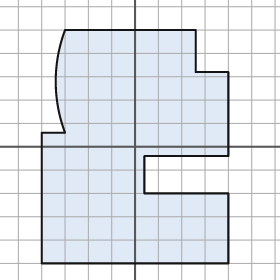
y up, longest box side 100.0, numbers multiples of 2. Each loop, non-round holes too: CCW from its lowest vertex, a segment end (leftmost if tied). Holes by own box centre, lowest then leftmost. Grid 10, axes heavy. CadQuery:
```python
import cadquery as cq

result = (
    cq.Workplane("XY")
    .moveTo(-40.0, -50.0)
    .lineTo(40.0, -50.0)
    .lineTo(40.0, -20.0)
    .lineTo(4.0, -20.0)
    .lineTo(4.0, -4.0)
    .lineTo(40.0, -4.0)
    .lineTo(40.0, 32.0)
    .lineTo(26.0, 32.0)
    .lineTo(26.0, 50.0)
    .lineTo(-30.0, 50.0)
    .threePointArc((-34.0, 28.0), (-30.0, 6.0))
    .lineTo(-40.0, 6.0)
    .close()
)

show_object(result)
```